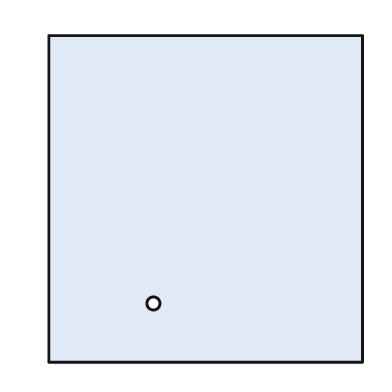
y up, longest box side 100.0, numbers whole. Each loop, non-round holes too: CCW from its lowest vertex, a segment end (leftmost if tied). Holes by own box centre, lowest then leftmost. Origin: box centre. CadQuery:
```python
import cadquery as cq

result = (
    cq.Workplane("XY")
    .moveTo(-48.0, -50.0)
    .lineTo(48.0, -50.0)
    .lineTo(48.0, 50.0)
    .lineTo(-48.0, 50.0)
    .close()
    .moveTo(-16.0, -32.0)
    .circle(2.0)
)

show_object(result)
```